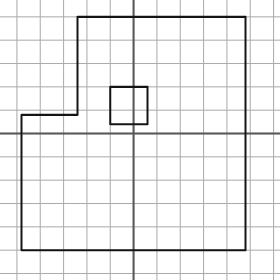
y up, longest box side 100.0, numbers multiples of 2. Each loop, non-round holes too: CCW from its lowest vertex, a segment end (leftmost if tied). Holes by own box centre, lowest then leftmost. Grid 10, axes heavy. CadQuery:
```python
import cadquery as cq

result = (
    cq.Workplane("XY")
    .moveTo(-48.0, -50.0)
    .lineTo(48.0, -50.0)
    .lineTo(48.0, 50.0)
    .lineTo(-24.0, 50.0)
    .lineTo(-24.0, 8.0)
    .lineTo(-48.0, 8.0)
    .close()
    .moveTo(-10.0, 4.0)
    .lineTo(6.0, 4.0)
    .lineTo(6.0, 20.0)
    .lineTo(-10.0, 20.0)
    .close()
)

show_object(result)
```